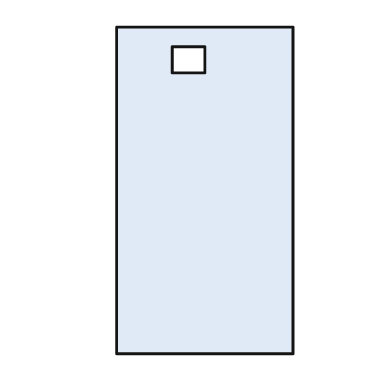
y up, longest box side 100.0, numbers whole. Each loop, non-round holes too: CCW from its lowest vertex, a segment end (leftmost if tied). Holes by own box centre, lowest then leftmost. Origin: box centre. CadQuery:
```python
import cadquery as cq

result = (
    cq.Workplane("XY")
    .moveTo(-27.0, -50.0)
    .lineTo(27.0, -50.0)
    .lineTo(27.0, 50.0)
    .lineTo(-27.0, 50.0)
    .close()
    .moveTo(-10.0, 36.0)
    .lineTo(0.0, 36.0)
    .lineTo(0.0, 44.0)
    .lineTo(-10.0, 44.0)
    .close()
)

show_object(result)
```